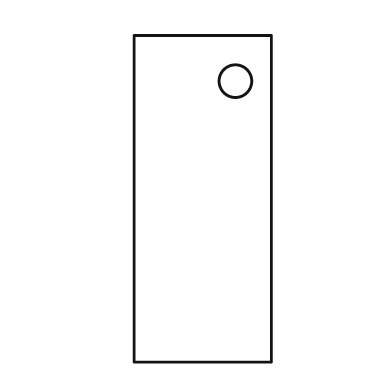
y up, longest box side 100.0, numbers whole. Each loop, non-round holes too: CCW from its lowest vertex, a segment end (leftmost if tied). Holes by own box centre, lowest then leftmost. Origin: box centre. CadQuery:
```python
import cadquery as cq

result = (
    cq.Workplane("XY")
    .moveTo(-21.0, -50.0)
    .lineTo(21.0, -50.0)
    .lineTo(21.0, 50.0)
    .lineTo(-21.0, 50.0)
    .close()
    .moveTo(10.0, 36.0)
    .circle(5.0)
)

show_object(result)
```